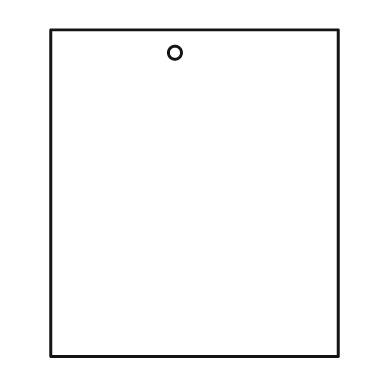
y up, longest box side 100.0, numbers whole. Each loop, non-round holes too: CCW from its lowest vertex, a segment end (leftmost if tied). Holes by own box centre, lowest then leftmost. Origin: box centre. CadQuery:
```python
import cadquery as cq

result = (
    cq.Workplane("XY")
    .moveTo(-44.0, -50.0)
    .lineTo(44.0, -50.0)
    .lineTo(44.0, 50.0)
    .lineTo(-44.0, 50.0)
    .close()
    .moveTo(-6.0, 43.0)
    .circle(2.0)
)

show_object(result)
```